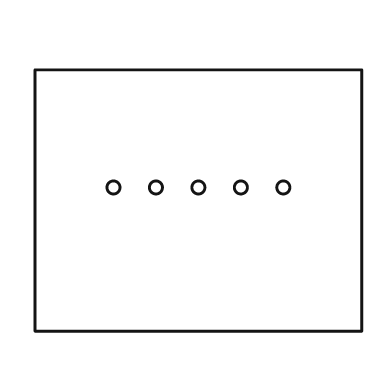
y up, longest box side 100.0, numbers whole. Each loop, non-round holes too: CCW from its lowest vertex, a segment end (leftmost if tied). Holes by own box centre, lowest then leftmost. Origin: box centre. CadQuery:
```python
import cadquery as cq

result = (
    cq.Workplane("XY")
    .moveTo(-50.0, -40.0)
    .lineTo(50.0, -40.0)
    .lineTo(50.0, 40.0)
    .lineTo(-50.0, 40.0)
    .close()
    .moveTo(-26.0, 4.0)
    .circle(2.0)
    .moveTo(-13.0, 4.0)
    .circle(2.0)
    .moveTo(0.0, 4.0)
    .circle(2.0)
    .moveTo(13.0, 4.0)
    .circle(2.0)
    .moveTo(26.0, 4.0)
    .circle(2.0)
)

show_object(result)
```